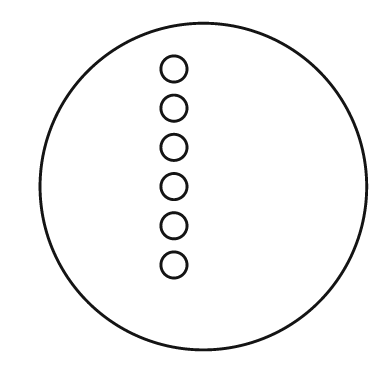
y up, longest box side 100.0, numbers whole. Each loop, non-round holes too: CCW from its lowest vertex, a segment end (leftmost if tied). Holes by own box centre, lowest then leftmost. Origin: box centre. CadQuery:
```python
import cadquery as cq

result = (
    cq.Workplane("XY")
    .moveTo(0.0, 0.0)
    .circle(50.0)
    .moveTo(-9.0, -24.0)
    .circle(4.0)
    .moveTo(-9.0, -12.0)
    .circle(4.0)
    .moveTo(-9.0, 0.0)
    .circle(4.0)
    .moveTo(-9.0, 12.0)
    .circle(4.0)
    .moveTo(-9.0, 24.0)
    .circle(4.0)
    .moveTo(-9.0, 36.0)
    .circle(4.0)
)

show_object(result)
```